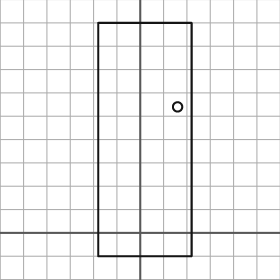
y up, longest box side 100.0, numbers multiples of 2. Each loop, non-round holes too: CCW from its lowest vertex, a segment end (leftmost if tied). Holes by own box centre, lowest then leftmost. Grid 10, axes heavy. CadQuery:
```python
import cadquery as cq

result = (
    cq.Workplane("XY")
    .moveTo(-18.0, -10.0)
    .lineTo(22.0, -10.0)
    .lineTo(22.0, 90.0)
    .lineTo(-18.0, 90.0)
    .close()
    .moveTo(16.0, 54.0)
    .circle(2.0)
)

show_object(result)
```